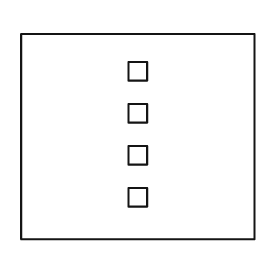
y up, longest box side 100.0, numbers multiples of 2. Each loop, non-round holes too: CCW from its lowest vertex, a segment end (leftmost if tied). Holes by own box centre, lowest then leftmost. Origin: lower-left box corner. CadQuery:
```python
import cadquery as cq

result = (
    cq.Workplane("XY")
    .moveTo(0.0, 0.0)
    .lineTo(100.0, 0.0)
    .lineTo(100.0, 88.0)
    .lineTo(0.0, 88.0)
    .close()
    .moveTo(46.0, 14.0)
    .lineTo(54.0, 14.0)
    .lineTo(54.0, 22.0)
    .lineTo(46.0, 22.0)
    .close()
    .moveTo(46.0, 32.0)
    .lineTo(54.0, 32.0)
    .lineTo(54.0, 40.0)
    .lineTo(46.0, 40.0)
    .close()
    .moveTo(46.0, 50.0)
    .lineTo(54.0, 50.0)
    .lineTo(54.0, 58.0)
    .lineTo(46.0, 58.0)
    .close()
    .moveTo(46.0, 68.0)
    .lineTo(54.0, 68.0)
    .lineTo(54.0, 76.0)
    .lineTo(46.0, 76.0)
    .close()
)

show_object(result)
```